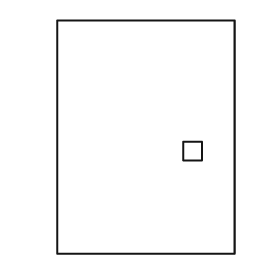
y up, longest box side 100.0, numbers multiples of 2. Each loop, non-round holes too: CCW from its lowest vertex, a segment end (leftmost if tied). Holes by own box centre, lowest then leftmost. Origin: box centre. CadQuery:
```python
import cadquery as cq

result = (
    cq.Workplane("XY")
    .moveTo(-38.0, -50.0)
    .lineTo(38.0, -50.0)
    .lineTo(38.0, 50.0)
    .lineTo(-38.0, 50.0)
    .close()
    .moveTo(16.0, -10.0)
    .lineTo(24.0, -10.0)
    .lineTo(24.0, -2.0)
    .lineTo(16.0, -2.0)
    .close()
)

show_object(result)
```